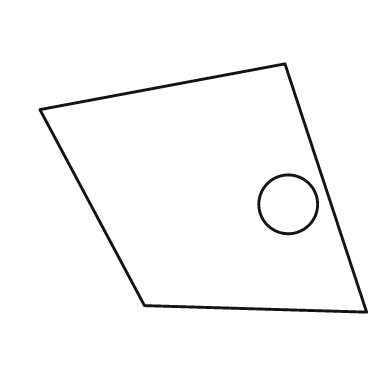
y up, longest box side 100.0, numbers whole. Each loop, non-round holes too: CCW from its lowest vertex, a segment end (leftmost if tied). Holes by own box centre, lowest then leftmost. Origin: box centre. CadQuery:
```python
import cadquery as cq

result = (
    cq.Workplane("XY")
    .moveTo(50.0, -38.0)
    .lineTo(25.0, 38.0)
    .lineTo(-50.0, 24.0)
    .lineTo(-18.0, -36.0)
    .close()
    .moveTo(26.0, -5.0)
    .circle(9.0)
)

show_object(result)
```